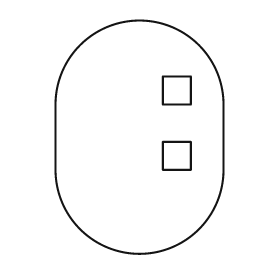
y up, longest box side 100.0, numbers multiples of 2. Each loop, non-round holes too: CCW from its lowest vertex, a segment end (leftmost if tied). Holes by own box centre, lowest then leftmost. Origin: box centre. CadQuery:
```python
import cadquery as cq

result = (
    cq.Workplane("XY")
    .moveTo(-36.0, -14.0)
    .threePointArc((0.0, -50.0), (36.0, -14.0))
    .lineTo(36.0, 14.0)
    .threePointArc((0.0, 50.0), (-36.0, 14.0))
    .close()
    .moveTo(10.0, -14.0)
    .lineTo(22.0, -14.0)
    .lineTo(22.0, -2.0)
    .lineTo(10.0, -2.0)
    .close()
    .moveTo(10.0, 14.0)
    .lineTo(22.0, 14.0)
    .lineTo(22.0, 26.0)
    .lineTo(10.0, 26.0)
    .close()
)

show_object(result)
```